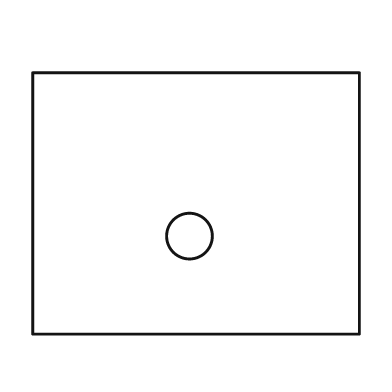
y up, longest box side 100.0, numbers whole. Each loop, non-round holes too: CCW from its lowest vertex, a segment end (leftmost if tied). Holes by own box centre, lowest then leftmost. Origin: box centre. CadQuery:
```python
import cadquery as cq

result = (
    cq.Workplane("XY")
    .moveTo(-50.0, -40.0)
    .lineTo(50.0, -40.0)
    .lineTo(50.0, 40.0)
    .lineTo(-50.0, 40.0)
    .close()
    .moveTo(-2.0, -10.0)
    .circle(7.0)
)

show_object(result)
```